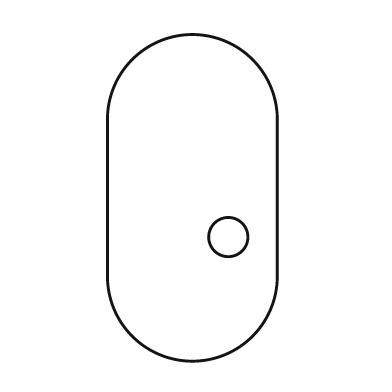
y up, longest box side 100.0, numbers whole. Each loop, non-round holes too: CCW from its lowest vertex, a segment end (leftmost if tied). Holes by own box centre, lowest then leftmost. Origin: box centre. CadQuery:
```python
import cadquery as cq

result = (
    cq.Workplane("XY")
    .moveTo(-26.0, -24.0)
    .threePointArc((0.0, -50.0), (26.0, -24.0))
    .lineTo(26.0, 24.0)
    .threePointArc((0.0, 50.0), (-26.0, 24.0))
    .close()
    .moveTo(11.0, -12.0)
    .circle(6.0)
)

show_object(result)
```